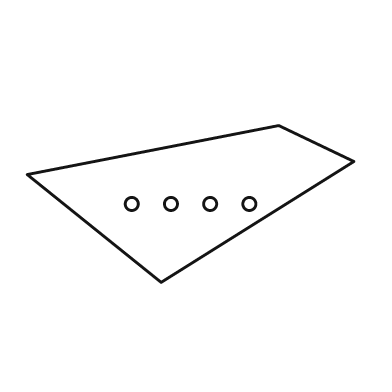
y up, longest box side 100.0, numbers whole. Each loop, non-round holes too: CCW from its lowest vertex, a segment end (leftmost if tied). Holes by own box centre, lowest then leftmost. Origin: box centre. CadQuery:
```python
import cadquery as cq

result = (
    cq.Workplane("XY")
    .moveTo(-9.0, -24.0)
    .lineTo(50.0, 13.0)
    .lineTo(27.0, 24.0)
    .lineTo(-50.0, 9.0)
    .close()
    .moveTo(-18.0, 0.0)
    .circle(2.0)
    .moveTo(-6.0, 0.0)
    .circle(2.0)
    .moveTo(6.0, 0.0)
    .circle(2.0)
    .moveTo(18.0, 0.0)
    .circle(2.0)
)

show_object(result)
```